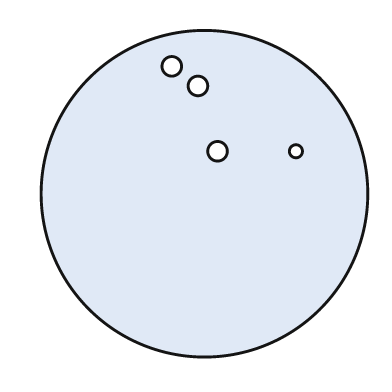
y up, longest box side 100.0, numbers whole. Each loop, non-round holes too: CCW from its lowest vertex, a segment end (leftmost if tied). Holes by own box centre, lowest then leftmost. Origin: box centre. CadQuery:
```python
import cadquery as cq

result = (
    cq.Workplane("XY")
    .moveTo(0.0, 0.0)
    .circle(50.0)
    .moveTo(4.0, 13.0)
    .circle(3.0)
    .moveTo(28.0, 13.0)
    .circle(2.0)
    .moveTo(-2.0, 33.0)
    .circle(3.0)
    .moveTo(-10.0, 39.0)
    .circle(3.0)
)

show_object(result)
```